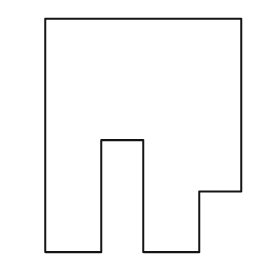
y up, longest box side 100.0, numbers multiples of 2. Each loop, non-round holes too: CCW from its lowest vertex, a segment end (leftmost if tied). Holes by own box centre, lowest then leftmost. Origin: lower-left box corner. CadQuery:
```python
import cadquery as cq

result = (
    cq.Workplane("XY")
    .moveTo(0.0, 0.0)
    .lineTo(24.0, 0.0)
    .lineTo(24.0, 48.0)
    .lineTo(42.0, 48.0)
    .lineTo(42.0, 0.0)
    .lineTo(66.0, 0.0)
    .lineTo(66.0, 26.0)
    .lineTo(84.0, 26.0)
    .lineTo(84.0, 100.0)
    .lineTo(0.0, 100.0)
    .close()
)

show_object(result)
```